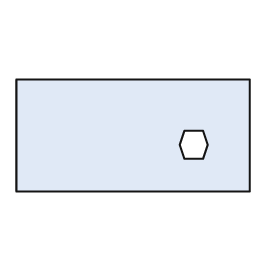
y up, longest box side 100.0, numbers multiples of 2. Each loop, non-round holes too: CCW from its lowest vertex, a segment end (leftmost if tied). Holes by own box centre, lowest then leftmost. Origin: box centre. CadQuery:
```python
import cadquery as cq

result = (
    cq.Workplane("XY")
    .moveTo(-50.0, -24.0)
    .lineTo(50.0, -24.0)
    .lineTo(50.0, 24.0)
    .lineTo(-50.0, 24.0)
    .close()
    .moveTo(22.0, -10.0)
    .lineTo(30.0, -10.0)
    .lineTo(32.0, -4.0)
    .lineTo(30.0, 2.0)
    .lineTo(22.0, 2.0)
    .lineTo(20.0, -4.0)
    .close()
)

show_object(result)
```